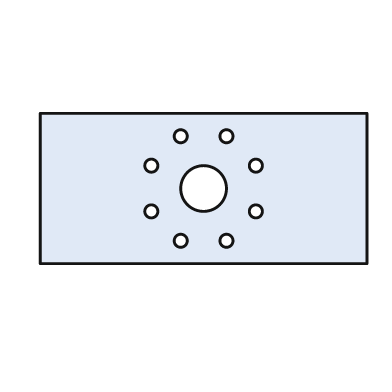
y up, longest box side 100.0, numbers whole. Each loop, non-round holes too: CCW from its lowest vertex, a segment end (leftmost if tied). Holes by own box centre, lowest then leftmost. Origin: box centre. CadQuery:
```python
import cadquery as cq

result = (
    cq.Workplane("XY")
    .moveTo(-50.0, -23.0)
    .lineTo(50.0, -23.0)
    .lineTo(50.0, 23.0)
    .lineTo(-50.0, 23.0)
    .close()
    .moveTo(-7.0, -16.0)
    .circle(2.0)
    .moveTo(7.0, -16.0)
    .circle(2.0)
    .moveTo(-16.0, -7.0)
    .circle(2.0)
    .moveTo(16.0, -7.0)
    .circle(2.0)
    .moveTo(0.0, 0.0)
    .circle(7.0)
    .moveTo(-16.0, 7.0)
    .circle(2.0)
    .moveTo(16.0, 7.0)
    .circle(2.0)
    .moveTo(-7.0, 16.0)
    .circle(2.0)
    .moveTo(7.0, 16.0)
    .circle(2.0)
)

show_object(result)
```